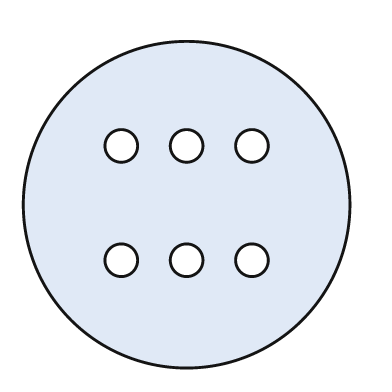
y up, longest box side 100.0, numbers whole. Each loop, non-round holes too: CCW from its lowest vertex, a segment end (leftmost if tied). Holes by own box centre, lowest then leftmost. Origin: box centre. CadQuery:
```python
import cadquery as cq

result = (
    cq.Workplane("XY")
    .moveTo(0.0, 0.0)
    .circle(50.0)
    .moveTo(-20.0, -17.0)
    .circle(5.0)
    .moveTo(0.0, -17.0)
    .circle(5.0)
    .moveTo(20.0, -17.0)
    .circle(5.0)
    .moveTo(-20.0, 18.0)
    .circle(5.0)
    .moveTo(0.0, 18.0)
    .circle(5.0)
    .moveTo(20.0, 18.0)
    .circle(5.0)
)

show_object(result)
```